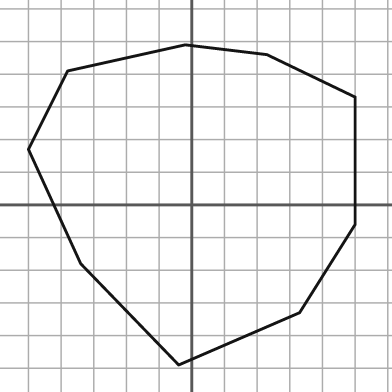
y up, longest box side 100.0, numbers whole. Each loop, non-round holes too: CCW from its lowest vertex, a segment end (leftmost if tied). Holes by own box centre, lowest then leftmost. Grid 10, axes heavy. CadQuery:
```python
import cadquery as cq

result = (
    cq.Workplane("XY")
    .moveTo(-4.0, -49.0)
    .lineTo(33.0, -33.0)
    .lineTo(50.0, -6.0)
    .lineTo(50.0, 33.0)
    .lineTo(23.0, 46.0)
    .lineTo(-2.0, 49.0)
    .lineTo(-38.0, 41.0)
    .lineTo(-50.0, 17.0)
    .lineTo(-34.0, -18.0)
    .close()
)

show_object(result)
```